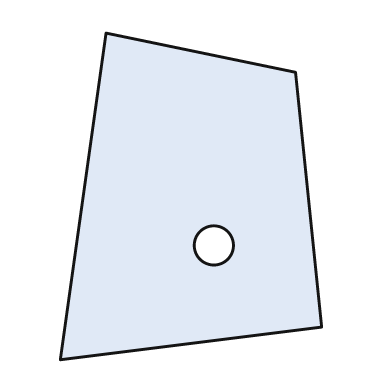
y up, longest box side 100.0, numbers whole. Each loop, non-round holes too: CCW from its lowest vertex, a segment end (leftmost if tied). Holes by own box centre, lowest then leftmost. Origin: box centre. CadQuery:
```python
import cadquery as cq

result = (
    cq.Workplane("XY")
    .moveTo(-40.0, -50.0)
    .lineTo(40.0, -40.0)
    .lineTo(32.0, 38.0)
    .lineTo(-26.0, 50.0)
    .close()
    .moveTo(7.0, -15.0)
    .circle(6.0)
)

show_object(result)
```